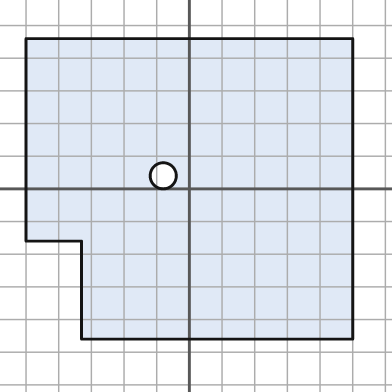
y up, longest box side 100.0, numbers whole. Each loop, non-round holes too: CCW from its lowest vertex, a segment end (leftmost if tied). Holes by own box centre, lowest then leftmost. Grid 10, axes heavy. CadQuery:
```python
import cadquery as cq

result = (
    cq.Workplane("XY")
    .moveTo(-33.0, -46.0)
    .lineTo(50.0, -46.0)
    .lineTo(50.0, 46.0)
    .lineTo(-50.0, 46.0)
    .lineTo(-50.0, -16.0)
    .lineTo(-33.0, -16.0)
    .close()
    .moveTo(-8.0, 4.0)
    .circle(4.0)
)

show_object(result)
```